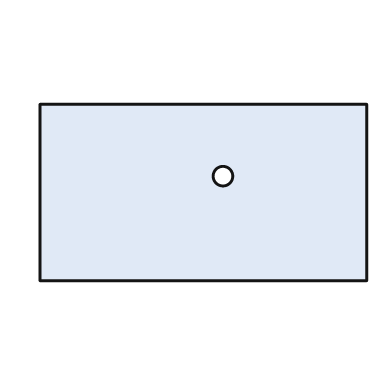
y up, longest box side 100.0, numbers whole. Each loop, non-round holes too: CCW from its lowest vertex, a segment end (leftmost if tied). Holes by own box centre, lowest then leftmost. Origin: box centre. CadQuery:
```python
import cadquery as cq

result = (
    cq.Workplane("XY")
    .moveTo(-50.0, -27.0)
    .lineTo(50.0, -27.0)
    .lineTo(50.0, 27.0)
    .lineTo(-50.0, 27.0)
    .close()
    .moveTo(6.0, 5.0)
    .circle(3.0)
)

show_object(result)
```